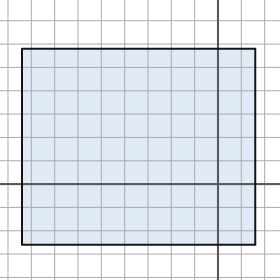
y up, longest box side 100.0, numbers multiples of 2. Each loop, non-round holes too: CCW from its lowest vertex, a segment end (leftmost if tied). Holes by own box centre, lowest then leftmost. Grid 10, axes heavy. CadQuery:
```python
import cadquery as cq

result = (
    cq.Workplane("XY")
    .moveTo(-84.0, -26.0)
    .lineTo(16.0, -26.0)
    .lineTo(16.0, 58.0)
    .lineTo(-84.0, 58.0)
    .close()
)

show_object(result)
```